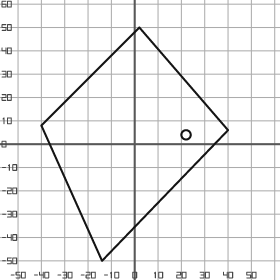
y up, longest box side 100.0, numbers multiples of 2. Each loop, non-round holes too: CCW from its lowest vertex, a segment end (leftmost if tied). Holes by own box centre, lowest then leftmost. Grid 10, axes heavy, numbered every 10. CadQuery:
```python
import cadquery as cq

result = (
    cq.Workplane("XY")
    .moveTo(-14.0, -50.0)
    .lineTo(40.0, 6.0)
    .lineTo(2.0, 50.0)
    .lineTo(-40.0, 8.0)
    .close()
    .moveTo(22.0, 4.0)
    .circle(2.0)
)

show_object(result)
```